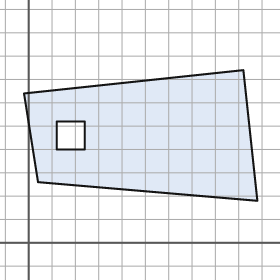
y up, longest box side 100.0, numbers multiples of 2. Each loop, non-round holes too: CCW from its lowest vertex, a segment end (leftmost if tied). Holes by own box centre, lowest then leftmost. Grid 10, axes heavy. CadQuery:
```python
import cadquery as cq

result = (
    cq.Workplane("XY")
    .moveTo(98.0, 18.0)
    .lineTo(92.0, 74.0)
    .lineTo(-2.0, 64.0)
    .lineTo(4.0, 26.0)
    .close()
    .moveTo(12.0, 40.0)
    .lineTo(24.0, 40.0)
    .lineTo(24.0, 52.0)
    .lineTo(12.0, 52.0)
    .close()
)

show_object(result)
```